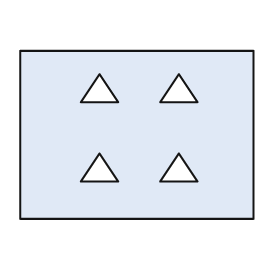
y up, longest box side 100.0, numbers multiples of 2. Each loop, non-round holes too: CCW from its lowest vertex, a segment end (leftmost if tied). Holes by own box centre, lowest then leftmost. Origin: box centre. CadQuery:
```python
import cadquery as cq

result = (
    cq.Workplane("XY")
    .moveTo(-50.0, -36.0)
    .lineTo(50.0, -36.0)
    .lineTo(50.0, 36.0)
    .lineTo(-50.0, 36.0)
    .close()
    .moveTo(-24.0, -20.0)
    .lineTo(-8.0, -20.0)
    .lineTo(-16.0, -8.0)
    .close()
    .moveTo(10.0, -20.0)
    .lineTo(26.0, -20.0)
    .lineTo(18.0, -8.0)
    .close()
    .moveTo(-24.0, 14.0)
    .lineTo(-8.0, 14.0)
    .lineTo(-16.0, 26.0)
    .close()
    .moveTo(10.0, 14.0)
    .lineTo(26.0, 14.0)
    .lineTo(18.0, 26.0)
    .close()
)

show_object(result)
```